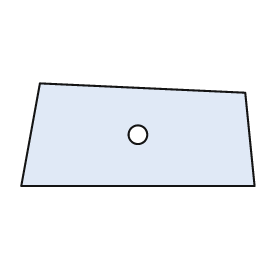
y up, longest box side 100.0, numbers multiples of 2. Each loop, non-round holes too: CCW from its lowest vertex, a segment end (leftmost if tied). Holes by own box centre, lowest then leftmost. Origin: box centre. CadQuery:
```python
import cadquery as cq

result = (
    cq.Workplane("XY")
    .moveTo(-50.0, -22.0)
    .lineTo(50.0, -22.0)
    .lineTo(46.0, 18.0)
    .lineTo(-42.0, 22.0)
    .close()
    .moveTo(0.0, 0.0)
    .circle(4.0)
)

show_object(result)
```